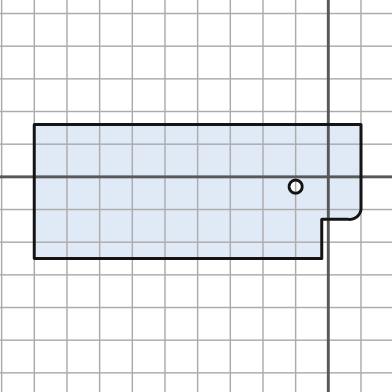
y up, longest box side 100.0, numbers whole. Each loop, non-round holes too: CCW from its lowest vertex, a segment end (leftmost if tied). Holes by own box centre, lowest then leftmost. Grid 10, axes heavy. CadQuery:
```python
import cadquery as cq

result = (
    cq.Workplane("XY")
    .moveTo(-90.0, -25.0)
    .lineTo(-2.0, -25.0)
    .lineTo(-2.0, -13.0)
    .lineTo(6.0, -13.0)
    .threePointArc((9.0, -12.0), (10.0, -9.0))
    .lineTo(10.0, 16.0)
    .lineTo(-90.0, 16.0)
    .close()
    .moveTo(-10.0, -3.0)
    .circle(2.0)
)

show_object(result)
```